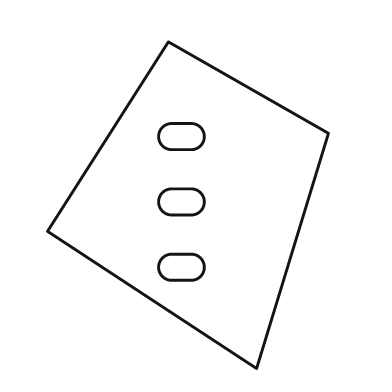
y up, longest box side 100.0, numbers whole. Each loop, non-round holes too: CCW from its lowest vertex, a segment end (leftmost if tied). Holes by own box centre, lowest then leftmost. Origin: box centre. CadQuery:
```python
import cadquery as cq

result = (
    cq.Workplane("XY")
    .moveTo(21.0, -50.0)
    .lineTo(43.0, 22.0)
    .lineTo(-6.0, 50.0)
    .lineTo(-43.0, -8.0)
    .close()
    .moveTo(-5.0, -23.0)
    .lineTo(1.0, -23.0)
    .threePointArc((5.0, -19.0), (1.0, -15.0))
    .lineTo(-5.0, -15.0)
    .threePointArc((-9.0, -19.0), (-5.0, -23.0))
    .close()
    .moveTo(-5.0, -3.0)
    .lineTo(1.0, -3.0)
    .threePointArc((5.0, 1.0), (1.0, 5.0))
    .lineTo(-5.0, 5.0)
    .threePointArc((-9.0, 1.0), (-5.0, -3.0))
    .close()
    .moveTo(-5.0, 17.0)
    .lineTo(1.0, 17.0)
    .threePointArc((5.0, 21.0), (1.0, 25.0))
    .lineTo(-5.0, 25.0)
    .threePointArc((-9.0, 21.0), (-5.0, 17.0))
    .close()
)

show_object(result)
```